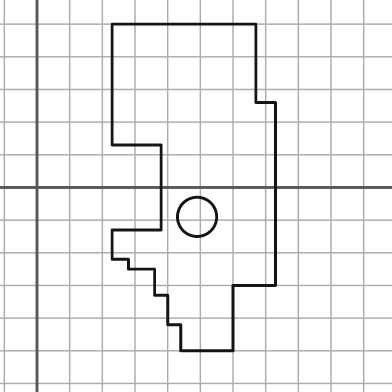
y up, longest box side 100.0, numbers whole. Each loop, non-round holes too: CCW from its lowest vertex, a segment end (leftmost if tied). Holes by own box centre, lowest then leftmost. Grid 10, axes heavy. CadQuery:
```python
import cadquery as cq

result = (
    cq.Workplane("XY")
    .moveTo(44.0, -50.0)
    .lineTo(60.0, -50.0)
    .lineTo(60.0, -30.0)
    .lineTo(73.0, -30.0)
    .lineTo(73.0, 26.0)
    .lineTo(67.0, 26.0)
    .lineTo(67.0, 50.0)
    .lineTo(23.0, 50.0)
    .lineTo(23.0, 13.0)
    .lineTo(38.0, 13.0)
    .lineTo(38.0, -13.0)
    .lineTo(23.0, -13.0)
    .lineTo(23.0, -22.0)
    .lineTo(28.0, -22.0)
    .lineTo(28.0, -25.0)
    .lineTo(36.0, -25.0)
    .lineTo(36.0, -33.0)
    .lineTo(40.0, -33.0)
    .lineTo(40.0, -42.0)
    .lineTo(44.0, -42.0)
    .close()
    .moveTo(49.0, -9.0)
    .circle(6.0)
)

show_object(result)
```